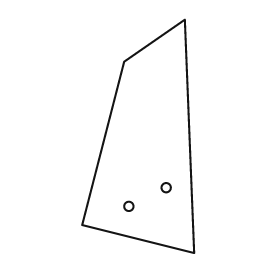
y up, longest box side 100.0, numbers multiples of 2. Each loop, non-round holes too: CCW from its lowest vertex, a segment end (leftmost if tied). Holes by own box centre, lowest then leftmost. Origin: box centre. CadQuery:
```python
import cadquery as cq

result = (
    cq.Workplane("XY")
    .moveTo(24.0, -50.0)
    .lineTo(20.0, 50.0)
    .lineTo(-6.0, 32.0)
    .lineTo(-24.0, -38.0)
    .close()
    .moveTo(-4.0, -30.0)
    .circle(2.0)
    .moveTo(12.0, -22.0)
    .circle(2.0)
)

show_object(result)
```